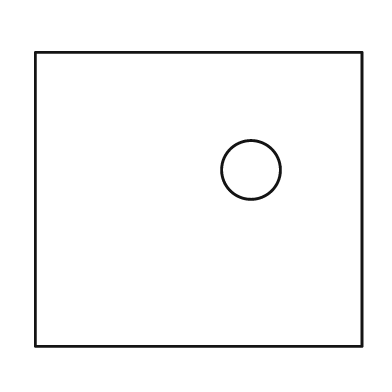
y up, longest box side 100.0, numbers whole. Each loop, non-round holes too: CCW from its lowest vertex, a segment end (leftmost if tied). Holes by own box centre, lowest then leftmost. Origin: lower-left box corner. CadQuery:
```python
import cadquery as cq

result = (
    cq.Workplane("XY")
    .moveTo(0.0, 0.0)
    .lineTo(100.0, 0.0)
    .lineTo(100.0, 90.0)
    .lineTo(0.0, 90.0)
    .close()
    .moveTo(66.0, 54.0)
    .circle(9.0)
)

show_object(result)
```